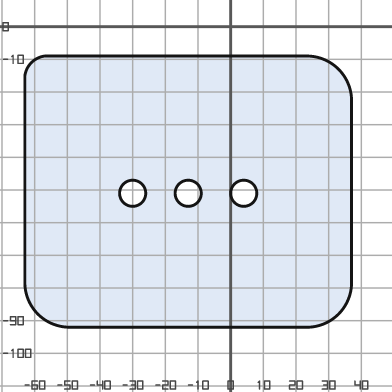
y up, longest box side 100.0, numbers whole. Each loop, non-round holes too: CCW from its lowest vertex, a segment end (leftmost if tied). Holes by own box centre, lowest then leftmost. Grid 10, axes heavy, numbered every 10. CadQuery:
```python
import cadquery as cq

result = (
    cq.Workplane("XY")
    .moveTo(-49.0, -92.0)
    .lineTo(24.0, -92.0)
    .threePointArc((33.0, -88.0), (37.0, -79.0))
    .lineTo(37.0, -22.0)
    .threePointArc((33.0, -13.0), (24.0, -9.0))
    .lineTo(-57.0, -9.0)
    .threePointArc((-61.0, -11.0), (-63.0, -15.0))
    .lineTo(-63.0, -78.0)
    .threePointArc((-59.0, -88.0), (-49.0, -92.0))
    .close()
    .moveTo(-30.0, -51.0)
    .circle(4.0)
    .moveTo(-13.0, -51.0)
    .circle(4.0)
    .moveTo(4.0, -51.0)
    .circle(4.0)
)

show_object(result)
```